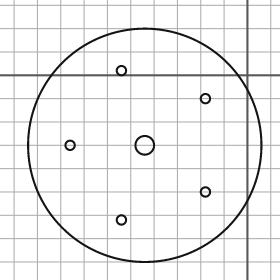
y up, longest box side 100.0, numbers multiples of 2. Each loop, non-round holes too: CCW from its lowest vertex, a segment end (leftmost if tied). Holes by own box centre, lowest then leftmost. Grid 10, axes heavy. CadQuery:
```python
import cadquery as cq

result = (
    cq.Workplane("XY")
    .moveTo(-44.0, -30.0)
    .circle(50.0)
    .moveTo(-54.0, -62.0)
    .circle(2.0)
    .moveTo(-18.0, -50.0)
    .circle(2.0)
    .moveTo(-76.0, -30.0)
    .circle(2.0)
    .moveTo(-44.0, -30.0)
    .circle(4.0)
    .moveTo(-18.0, -10.0)
    .circle(2.0)
    .moveTo(-54.0, 2.0)
    .circle(2.0)
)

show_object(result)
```